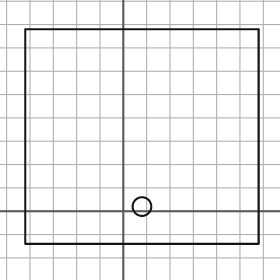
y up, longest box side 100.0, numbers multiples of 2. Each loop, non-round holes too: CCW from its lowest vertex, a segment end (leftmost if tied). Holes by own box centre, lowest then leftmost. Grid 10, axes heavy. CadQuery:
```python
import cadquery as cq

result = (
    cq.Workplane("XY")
    .moveTo(-42.0, -14.0)
    .lineTo(58.0, -14.0)
    .lineTo(58.0, 78.0)
    .lineTo(-42.0, 78.0)
    .close()
    .moveTo(8.0, 2.0)
    .circle(4.0)
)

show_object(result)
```